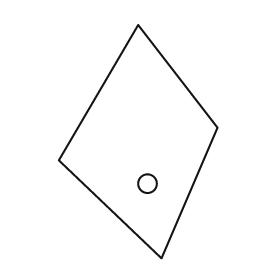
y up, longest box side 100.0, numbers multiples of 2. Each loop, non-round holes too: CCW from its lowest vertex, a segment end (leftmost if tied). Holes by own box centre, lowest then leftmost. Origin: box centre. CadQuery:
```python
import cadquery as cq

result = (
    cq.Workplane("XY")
    .moveTo(10.0, -50.0)
    .lineTo(34.0, 6.0)
    .lineTo(0.0, 50.0)
    .lineTo(-34.0, -8.0)
    .close()
    .moveTo(4.0, -18.0)
    .circle(4.0)
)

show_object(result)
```